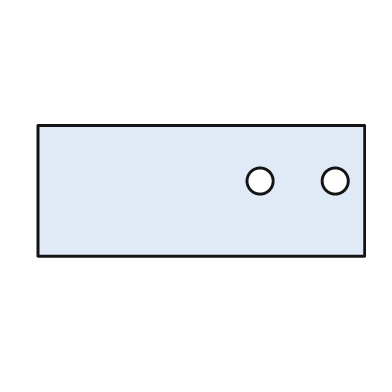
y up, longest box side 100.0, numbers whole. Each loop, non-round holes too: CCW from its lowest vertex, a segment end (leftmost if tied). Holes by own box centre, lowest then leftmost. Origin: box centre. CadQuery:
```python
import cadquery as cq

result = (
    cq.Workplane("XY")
    .moveTo(-50.0, -20.0)
    .lineTo(50.0, -20.0)
    .lineTo(50.0, 20.0)
    .lineTo(-50.0, 20.0)
    .close()
    .moveTo(18.0, 3.0)
    .circle(4.0)
    .moveTo(41.0, 3.0)
    .circle(4.0)
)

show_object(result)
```